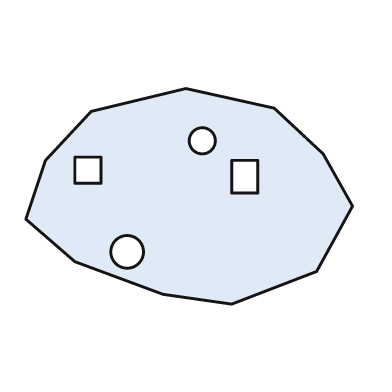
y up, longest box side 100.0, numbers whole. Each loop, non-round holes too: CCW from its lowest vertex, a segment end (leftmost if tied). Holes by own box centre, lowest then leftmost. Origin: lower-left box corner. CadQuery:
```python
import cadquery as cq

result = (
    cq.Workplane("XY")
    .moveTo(63.0, 0.0)
    .lineTo(89.0, 10.0)
    .lineTo(100.0, 30.0)
    .lineTo(91.0, 46.0)
    .lineTo(76.0, 60.0)
    .lineTo(49.0, 66.0)
    .lineTo(20.0, 59.0)
    .lineTo(6.0, 44.0)
    .lineTo(0.0, 26.0)
    .lineTo(15.0, 13.0)
    .lineTo(42.0, 3.0)
    .close()
    .moveTo(31.0, 16.0)
    .circle(5.0)
    .moveTo(63.0, 34.0)
    .lineTo(71.0, 34.0)
    .lineTo(71.0, 44.0)
    .lineTo(63.0, 44.0)
    .close()
    .moveTo(15.0, 37.0)
    .lineTo(23.0, 37.0)
    .lineTo(23.0, 45.0)
    .lineTo(15.0, 45.0)
    .close()
    .moveTo(54.0, 50.0)
    .circle(4.0)
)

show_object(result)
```